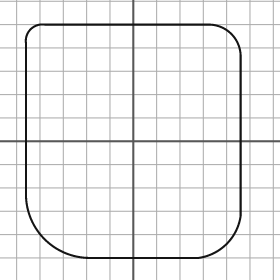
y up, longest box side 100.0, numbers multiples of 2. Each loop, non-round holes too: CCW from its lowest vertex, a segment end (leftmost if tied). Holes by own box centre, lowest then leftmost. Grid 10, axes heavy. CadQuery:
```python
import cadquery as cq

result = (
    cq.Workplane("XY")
    .moveTo(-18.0, -50.0)
    .lineTo(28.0, -50.0)
    .threePointArc((40.0, -44.0), (46.0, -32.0))
    .lineTo(46.0, 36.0)
    .threePointArc((42.0, 46.0), (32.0, 50.0))
    .lineTo(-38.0, 50.0)
    .threePointArc((-44.0, 48.0), (-46.0, 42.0))
    .lineTo(-46.0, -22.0)
    .threePointArc((-38.0, -42.0), (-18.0, -50.0))
    .close()
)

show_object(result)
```